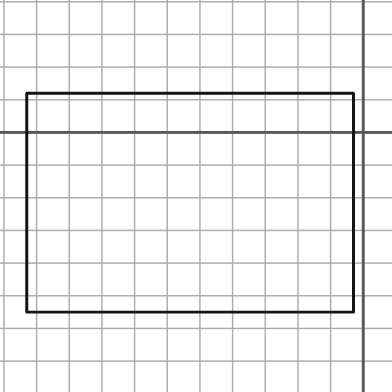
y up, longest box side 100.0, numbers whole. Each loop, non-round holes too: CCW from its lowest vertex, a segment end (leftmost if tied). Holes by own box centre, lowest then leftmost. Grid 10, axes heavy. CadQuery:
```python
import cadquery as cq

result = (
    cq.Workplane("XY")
    .moveTo(-103.0, -55.0)
    .lineTo(-3.0, -55.0)
    .lineTo(-3.0, 12.0)
    .lineTo(-103.0, 12.0)
    .close()
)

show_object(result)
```